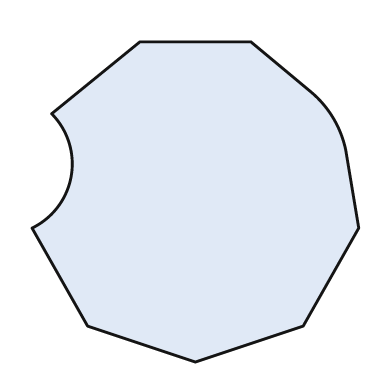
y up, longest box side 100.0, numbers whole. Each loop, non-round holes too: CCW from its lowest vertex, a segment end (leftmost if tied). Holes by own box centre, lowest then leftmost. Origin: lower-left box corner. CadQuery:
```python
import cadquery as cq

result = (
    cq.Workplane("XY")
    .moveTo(50.0, 0.0)
    .lineTo(83.0, 11.0)
    .lineTo(100.0, 41.0)
    .lineTo(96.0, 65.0)
    .threePointArc((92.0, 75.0), (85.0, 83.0))
    .lineTo(67.0, 98.0)
    .lineTo(33.0, 98.0)
    .lineTo(6.0, 76.0)
    .threePointArc((12.0, 57.0), (0.0, 41.0))
    .lineTo(17.0, 11.0)
    .close()
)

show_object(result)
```